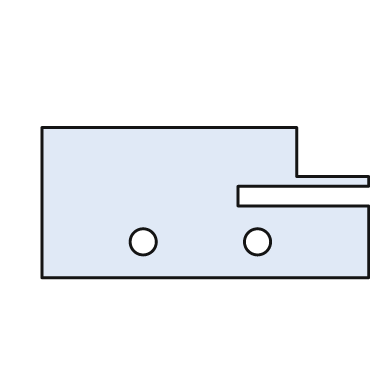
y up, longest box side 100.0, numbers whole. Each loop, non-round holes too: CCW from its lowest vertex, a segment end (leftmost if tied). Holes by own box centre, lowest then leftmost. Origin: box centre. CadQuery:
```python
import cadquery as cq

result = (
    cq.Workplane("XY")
    .moveTo(-50.0, -23.0)
    .lineTo(50.0, -23.0)
    .lineTo(50.0, -1.0)
    .lineTo(10.0, -1.0)
    .lineTo(10.0, 5.0)
    .lineTo(50.0, 5.0)
    .lineTo(50.0, 8.0)
    .lineTo(28.0, 8.0)
    .lineTo(28.0, 23.0)
    .lineTo(-50.0, 23.0)
    .close()
    .moveTo(-19.0, -12.0)
    .circle(4.0)
    .moveTo(16.0, -12.0)
    .circle(4.0)
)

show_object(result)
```